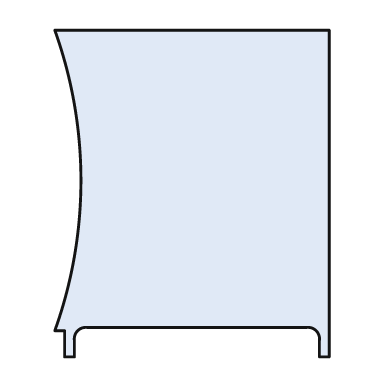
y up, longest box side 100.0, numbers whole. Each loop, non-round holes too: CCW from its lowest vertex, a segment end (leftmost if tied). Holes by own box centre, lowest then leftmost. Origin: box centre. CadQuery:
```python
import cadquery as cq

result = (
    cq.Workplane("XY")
    .moveTo(-39.0, -50.0)
    .lineTo(-36.0, -50.0)
    .lineTo(-36.0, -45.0)
    .threePointArc((-35.0, -42.0), (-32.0, -41.0))
    .lineTo(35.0, -41.0)
    .threePointArc((38.0, -42.0), (39.0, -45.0))
    .lineTo(39.0, -50.0)
    .lineTo(42.0, -50.0)
    .lineTo(42.0, 50.0)
    .lineTo(-42.0, 50.0)
    .threePointArc((-34.0, 4.0), (-42.0, -42.0))
    .lineTo(-39.0, -42.0)
    .close()
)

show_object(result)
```